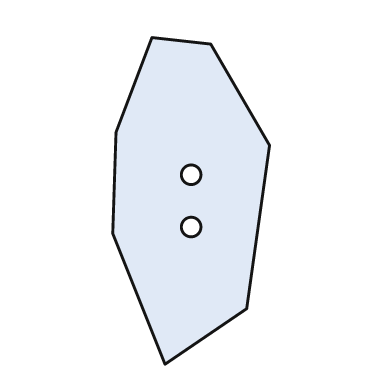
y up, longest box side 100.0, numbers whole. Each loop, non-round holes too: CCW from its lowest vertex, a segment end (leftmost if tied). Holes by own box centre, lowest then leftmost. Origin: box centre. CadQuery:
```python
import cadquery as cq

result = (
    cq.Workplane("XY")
    .moveTo(-8.0, -50.0)
    .lineTo(17.0, -33.0)
    .lineTo(24.0, 17.0)
    .lineTo(6.0, 48.0)
    .lineTo(-12.0, 50.0)
    .lineTo(-23.0, 21.0)
    .lineTo(-24.0, -10.0)
    .close()
    .moveTo(0.0, -8.0)
    .circle(3.0)
    .moveTo(0.0, 8.0)
    .circle(3.0)
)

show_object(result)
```